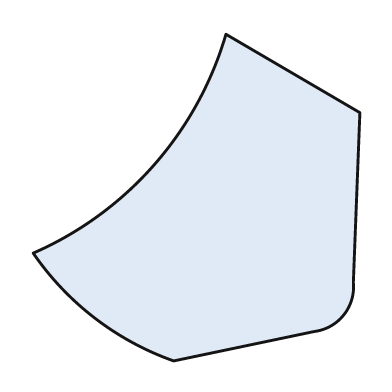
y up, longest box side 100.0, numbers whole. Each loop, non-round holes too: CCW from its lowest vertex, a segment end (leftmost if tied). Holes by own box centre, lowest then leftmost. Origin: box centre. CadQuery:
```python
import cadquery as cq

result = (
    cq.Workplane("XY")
    .moveTo(-7.0, -50.0)
    .lineTo(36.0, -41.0)
    .threePointArc((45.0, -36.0), (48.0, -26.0))
    .lineTo(50.0, 26.0)
    .lineTo(9.0, 50.0)
    .threePointArc((-13.0, 10.0), (-50.0, -17.0))
    .threePointArc((-31.0, -37.0), (-7.0, -50.0))
    .close()
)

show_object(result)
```